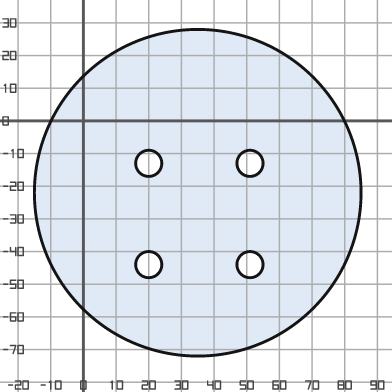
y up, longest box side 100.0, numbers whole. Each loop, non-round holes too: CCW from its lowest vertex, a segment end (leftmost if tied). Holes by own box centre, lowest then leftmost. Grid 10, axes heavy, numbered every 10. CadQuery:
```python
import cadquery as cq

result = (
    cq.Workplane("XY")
    .moveTo(35.0, -22.0)
    .circle(50.0)
    .moveTo(20.0, -44.0)
    .circle(4.0)
    .moveTo(51.0, -44.0)
    .circle(4.0)
    .moveTo(20.0, -13.0)
    .circle(4.0)
    .moveTo(51.0, -13.0)
    .circle(4.0)
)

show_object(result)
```